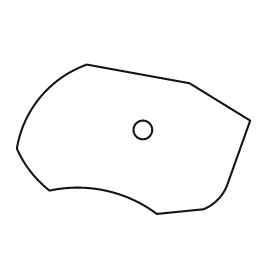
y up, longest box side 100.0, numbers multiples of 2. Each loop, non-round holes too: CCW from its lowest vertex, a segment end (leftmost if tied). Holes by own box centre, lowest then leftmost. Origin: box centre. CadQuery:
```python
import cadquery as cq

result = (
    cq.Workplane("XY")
    .moveTo(10.0, -32.0)
    .lineTo(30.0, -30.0)
    .threePointArc((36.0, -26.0), (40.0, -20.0))
    .lineTo(50.0, 8.0)
    .lineTo(24.0, 24.0)
    .lineTo(-20.0, 32.0)
    .threePointArc((-40.0, 18.0), (-50.0, -4.0))
    .threePointArc((-44.0, -14.0), (-36.0, -22.0))
    .threePointArc((-12.0, -22.0), (10.0, -32.0))
    .close()
    .moveTo(4.0, 4.0)
    .circle(4.0)
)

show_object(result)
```